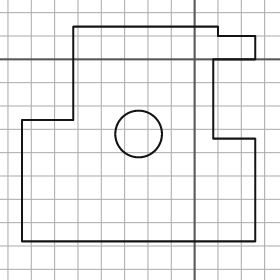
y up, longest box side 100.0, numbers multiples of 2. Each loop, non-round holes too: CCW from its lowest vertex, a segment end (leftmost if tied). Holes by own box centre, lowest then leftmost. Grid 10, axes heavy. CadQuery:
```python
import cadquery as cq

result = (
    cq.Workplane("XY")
    .moveTo(-74.0, -78.0)
    .lineTo(26.0, -78.0)
    .lineTo(26.0, -34.0)
    .lineTo(8.0, -34.0)
    .lineTo(8.0, 0.0)
    .lineTo(26.0, 0.0)
    .lineTo(26.0, 10.0)
    .lineTo(10.0, 10.0)
    .lineTo(10.0, 14.0)
    .lineTo(-52.0, 14.0)
    .lineTo(-52.0, -26.0)
    .lineTo(-74.0, -26.0)
    .close()
    .moveTo(-24.0, -32.0)
    .circle(10.0)
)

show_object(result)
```